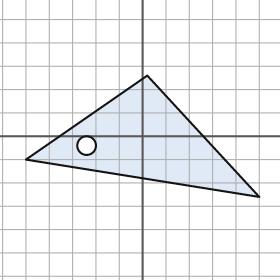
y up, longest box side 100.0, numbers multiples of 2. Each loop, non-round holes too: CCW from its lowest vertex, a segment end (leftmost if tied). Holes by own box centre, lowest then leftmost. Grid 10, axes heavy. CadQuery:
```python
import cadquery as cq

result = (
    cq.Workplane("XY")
    .moveTo(50.0, -26.0)
    .lineTo(2.0, 26.0)
    .lineTo(-50.0, -10.0)
    .close()
    .moveTo(-24.0, -4.0)
    .circle(4.0)
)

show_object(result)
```